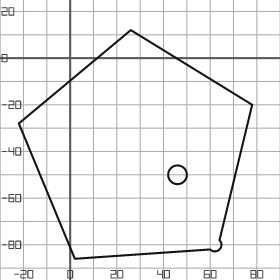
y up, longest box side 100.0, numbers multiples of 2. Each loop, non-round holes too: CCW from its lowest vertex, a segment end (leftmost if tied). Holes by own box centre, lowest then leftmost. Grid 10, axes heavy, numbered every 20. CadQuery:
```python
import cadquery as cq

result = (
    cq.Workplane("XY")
    .moveTo(2.0, -86.0)
    .lineTo(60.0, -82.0)
    .threePointArc((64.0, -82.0), (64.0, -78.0))
    .lineTo(78.0, -20.0)
    .lineTo(26.0, 12.0)
    .lineTo(-22.0, -28.0)
    .close()
    .moveTo(46.0, -50.0)
    .circle(4.0)
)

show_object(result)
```